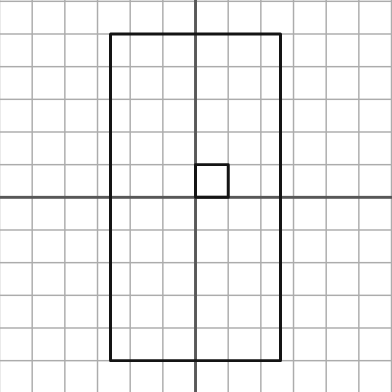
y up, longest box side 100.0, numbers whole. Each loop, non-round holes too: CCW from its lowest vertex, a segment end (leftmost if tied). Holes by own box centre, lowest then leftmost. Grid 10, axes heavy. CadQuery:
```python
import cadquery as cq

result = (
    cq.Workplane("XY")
    .moveTo(-26.0, -50.0)
    .lineTo(26.0, -50.0)
    .lineTo(26.0, 50.0)
    .lineTo(-26.0, 50.0)
    .close()
    .moveTo(0.0, 0.0)
    .lineTo(10.0, 0.0)
    .lineTo(10.0, 10.0)
    .lineTo(0.0, 10.0)
    .close()
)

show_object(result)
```